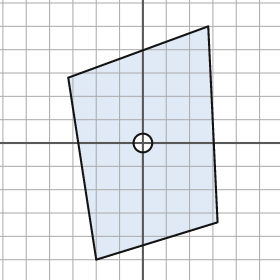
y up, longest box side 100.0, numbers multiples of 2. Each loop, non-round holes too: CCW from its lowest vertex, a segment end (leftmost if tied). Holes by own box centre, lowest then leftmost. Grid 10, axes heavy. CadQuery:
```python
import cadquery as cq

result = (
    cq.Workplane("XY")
    .moveTo(-20.0, -50.0)
    .lineTo(32.0, -34.0)
    .lineTo(28.0, 50.0)
    .lineTo(-32.0, 28.0)
    .close()
    .moveTo(0.0, 0.0)
    .circle(4.0)
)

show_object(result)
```